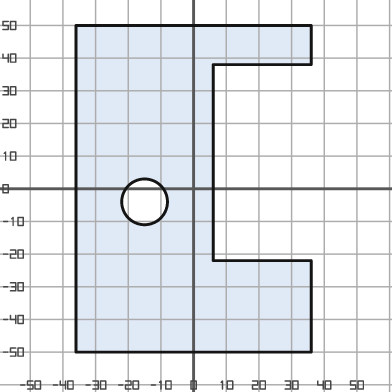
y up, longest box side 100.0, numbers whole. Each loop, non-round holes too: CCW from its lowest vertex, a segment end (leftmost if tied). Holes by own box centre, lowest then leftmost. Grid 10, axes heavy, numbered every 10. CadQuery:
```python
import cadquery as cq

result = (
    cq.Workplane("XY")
    .moveTo(-36.0, -50.0)
    .lineTo(36.0, -50.0)
    .lineTo(36.0, -22.0)
    .lineTo(6.0, -22.0)
    .lineTo(6.0, 38.0)
    .lineTo(36.0, 38.0)
    .lineTo(36.0, 50.0)
    .lineTo(-36.0, 50.0)
    .close()
    .moveTo(-15.0, -4.0)
    .circle(7.0)
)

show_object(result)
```